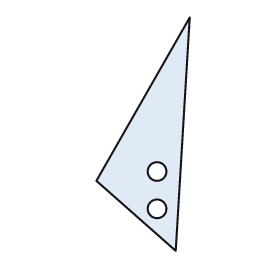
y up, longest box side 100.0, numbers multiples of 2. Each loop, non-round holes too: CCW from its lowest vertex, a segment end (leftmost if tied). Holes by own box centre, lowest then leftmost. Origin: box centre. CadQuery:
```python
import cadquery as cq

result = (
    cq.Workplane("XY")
    .moveTo(14.0, -50.0)
    .lineTo(20.0, 50.0)
    .lineTo(-20.0, -20.0)
    .close()
    .moveTo(6.0, -32.0)
    .circle(4.0)
    .moveTo(6.0, -16.0)
    .circle(4.0)
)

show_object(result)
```